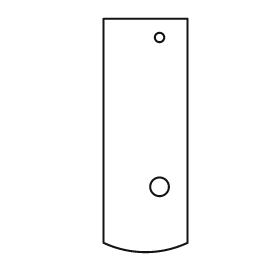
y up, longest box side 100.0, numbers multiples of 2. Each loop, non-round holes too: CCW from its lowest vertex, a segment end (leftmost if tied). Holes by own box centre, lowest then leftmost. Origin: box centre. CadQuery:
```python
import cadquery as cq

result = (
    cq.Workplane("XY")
    .moveTo(-18.0, -46.0)
    .threePointArc((0.0, -50.0), (18.0, -46.0))
    .lineTo(18.0, 50.0)
    .lineTo(-18.0, 50.0)
    .close()
    .moveTo(6.0, -22.0)
    .circle(4.0)
    .moveTo(6.0, 42.0)
    .circle(2.0)
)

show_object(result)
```